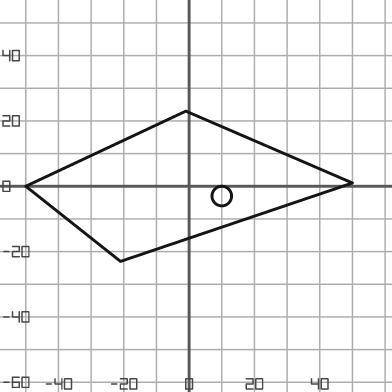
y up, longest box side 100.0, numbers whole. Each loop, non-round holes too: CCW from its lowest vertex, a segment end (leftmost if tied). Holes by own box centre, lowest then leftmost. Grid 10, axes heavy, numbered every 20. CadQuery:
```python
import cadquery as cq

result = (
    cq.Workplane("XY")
    .moveTo(-21.0, -23.0)
    .lineTo(50.0, 1.0)
    .lineTo(-1.0, 23.0)
    .lineTo(-50.0, 0.0)
    .close()
    .moveTo(10.0, -3.0)
    .circle(3.0)
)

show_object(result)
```